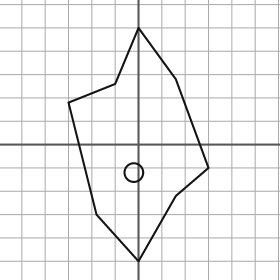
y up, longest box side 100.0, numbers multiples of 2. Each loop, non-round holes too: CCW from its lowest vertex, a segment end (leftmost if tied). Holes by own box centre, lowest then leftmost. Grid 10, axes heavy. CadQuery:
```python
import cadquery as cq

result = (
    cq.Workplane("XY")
    .moveTo(0.0, -50.0)
    .lineTo(16.0, -22.0)
    .lineTo(30.0, -10.0)
    .lineTo(16.0, 28.0)
    .lineTo(0.0, 50.0)
    .lineTo(-10.0, 26.0)
    .lineTo(-30.0, 18.0)
    .lineTo(-18.0, -30.0)
    .close()
    .moveTo(-2.0, -12.0)
    .circle(4.0)
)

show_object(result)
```